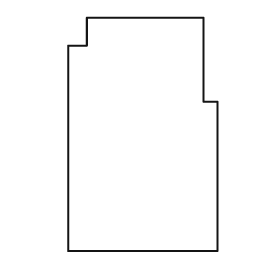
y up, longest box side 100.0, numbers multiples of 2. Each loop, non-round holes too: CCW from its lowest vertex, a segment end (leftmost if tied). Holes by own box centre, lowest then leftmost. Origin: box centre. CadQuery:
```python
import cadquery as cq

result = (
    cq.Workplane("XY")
    .moveTo(-32.0, -50.0)
    .lineTo(32.0, -50.0)
    .lineTo(32.0, 14.0)
    .lineTo(26.0, 14.0)
    .lineTo(26.0, 50.0)
    .lineTo(-24.0, 50.0)
    .lineTo(-24.0, 38.0)
    .lineTo(-32.0, 38.0)
    .close()
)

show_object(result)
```